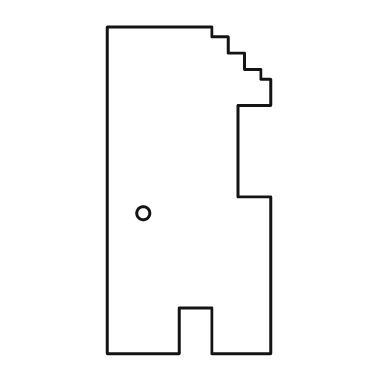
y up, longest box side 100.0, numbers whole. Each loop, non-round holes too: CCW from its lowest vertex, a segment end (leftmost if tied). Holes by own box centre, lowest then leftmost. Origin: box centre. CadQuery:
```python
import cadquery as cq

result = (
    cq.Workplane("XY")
    .moveTo(-25.0, -50.0)
    .lineTo(-3.0, -50.0)
    .lineTo(-3.0, -36.0)
    .lineTo(7.0, -36.0)
    .lineTo(7.0, -50.0)
    .lineTo(25.0, -50.0)
    .lineTo(25.0, -2.0)
    .lineTo(15.0, -2.0)
    .lineTo(15.0, 26.0)
    .lineTo(25.0, 26.0)
    .lineTo(25.0, 34.0)
    .lineTo(22.0, 34.0)
    .lineTo(22.0, 37.0)
    .lineTo(17.0, 37.0)
    .lineTo(17.0, 42.0)
    .lineTo(12.0, 42.0)
    .lineTo(12.0, 47.0)
    .lineTo(7.0, 47.0)
    .lineTo(7.0, 50.0)
    .lineTo(-25.0, 50.0)
    .close()
    .moveTo(-14.0, -7.0)
    .circle(2.0)
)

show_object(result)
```